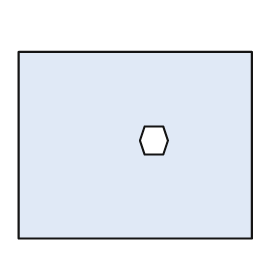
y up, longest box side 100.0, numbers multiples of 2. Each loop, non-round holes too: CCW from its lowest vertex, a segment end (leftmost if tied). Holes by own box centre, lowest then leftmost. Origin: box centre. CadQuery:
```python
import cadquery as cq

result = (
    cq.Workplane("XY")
    .moveTo(-50.0, -40.0)
    .lineTo(50.0, -40.0)
    .lineTo(50.0, 40.0)
    .lineTo(-50.0, 40.0)
    .close()
    .moveTo(4.0, -4.0)
    .lineTo(12.0, -4.0)
    .lineTo(14.0, 2.0)
    .lineTo(12.0, 8.0)
    .lineTo(4.0, 8.0)
    .lineTo(2.0, 2.0)
    .close()
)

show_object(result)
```